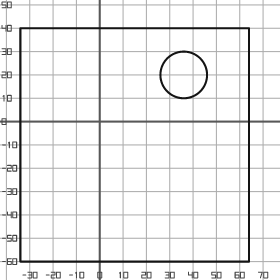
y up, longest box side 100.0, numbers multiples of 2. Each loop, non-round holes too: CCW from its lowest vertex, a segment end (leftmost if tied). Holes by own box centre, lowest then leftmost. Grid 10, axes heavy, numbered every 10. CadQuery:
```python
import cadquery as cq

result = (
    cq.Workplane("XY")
    .moveTo(-34.0, -60.0)
    .lineTo(64.0, -60.0)
    .lineTo(64.0, 40.0)
    .lineTo(-34.0, 40.0)
    .close()
    .moveTo(36.0, 20.0)
    .circle(10.0)
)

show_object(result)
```